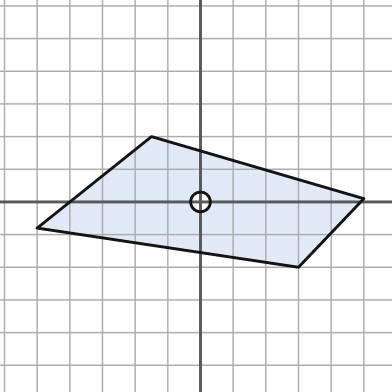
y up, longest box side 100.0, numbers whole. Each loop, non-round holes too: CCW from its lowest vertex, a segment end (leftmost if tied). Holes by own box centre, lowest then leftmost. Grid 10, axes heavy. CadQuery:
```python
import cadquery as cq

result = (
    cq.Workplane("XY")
    .moveTo(30.0, -20.0)
    .lineTo(50.0, 1.0)
    .lineTo(-15.0, 20.0)
    .lineTo(-50.0, -8.0)
    .close()
    .moveTo(0.0, 0.0)
    .circle(3.0)
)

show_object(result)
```